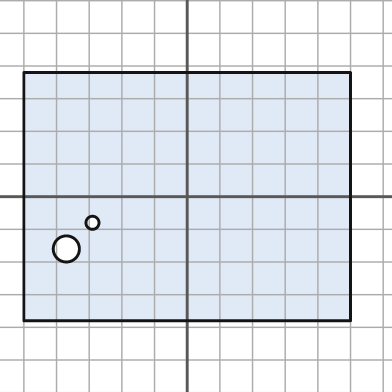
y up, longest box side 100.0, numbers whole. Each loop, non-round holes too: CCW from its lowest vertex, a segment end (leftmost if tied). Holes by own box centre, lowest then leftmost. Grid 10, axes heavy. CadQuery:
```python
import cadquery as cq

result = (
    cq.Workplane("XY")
    .moveTo(-50.0, -38.0)
    .lineTo(50.0, -38.0)
    .lineTo(50.0, 38.0)
    .lineTo(-50.0, 38.0)
    .close()
    .moveTo(-37.0, -16.0)
    .circle(4.0)
    .moveTo(-29.0, -8.0)
    .circle(2.0)
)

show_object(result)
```